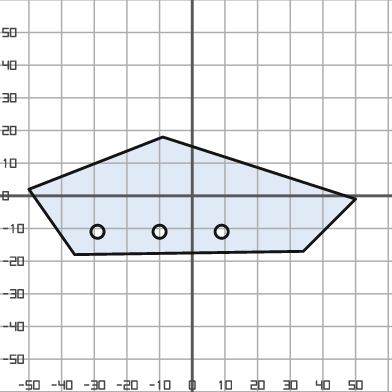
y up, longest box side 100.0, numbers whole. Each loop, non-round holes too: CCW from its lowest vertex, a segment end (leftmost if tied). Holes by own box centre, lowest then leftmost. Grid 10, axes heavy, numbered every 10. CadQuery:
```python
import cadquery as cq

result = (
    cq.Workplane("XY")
    .moveTo(-36.0, -18.0)
    .lineTo(34.0, -17.0)
    .lineTo(50.0, -1.0)
    .lineTo(-9.0, 18.0)
    .lineTo(-50.0, 2.0)
    .close()
    .moveTo(-29.0, -11.0)
    .circle(2.0)
    .moveTo(-10.0, -11.0)
    .circle(2.0)
    .moveTo(9.0, -11.0)
    .circle(2.0)
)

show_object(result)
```